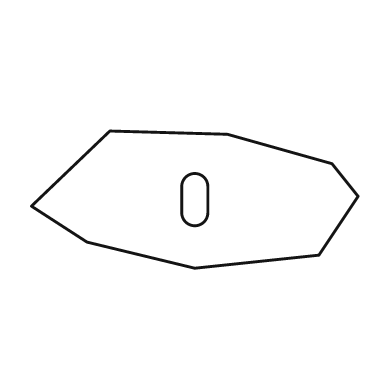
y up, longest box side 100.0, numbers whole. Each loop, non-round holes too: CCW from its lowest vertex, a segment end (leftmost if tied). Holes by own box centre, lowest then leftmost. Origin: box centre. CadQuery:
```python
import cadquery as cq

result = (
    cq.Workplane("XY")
    .moveTo(0.0, -21.0)
    .lineTo(38.0, -17.0)
    .lineTo(50.0, 1.0)
    .lineTo(42.0, 11.0)
    .lineTo(10.0, 20.0)
    .lineTo(-26.0, 21.0)
    .lineTo(-50.0, -2.0)
    .lineTo(-33.0, -13.0)
    .close()
    .moveTo(-4.0, -4.0)
    .threePointArc((0.0, -8.0), (4.0, -4.0))
    .lineTo(4.0, 4.0)
    .threePointArc((0.0, 8.0), (-4.0, 4.0))
    .close()
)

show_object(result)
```